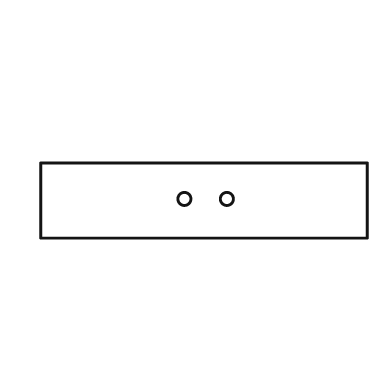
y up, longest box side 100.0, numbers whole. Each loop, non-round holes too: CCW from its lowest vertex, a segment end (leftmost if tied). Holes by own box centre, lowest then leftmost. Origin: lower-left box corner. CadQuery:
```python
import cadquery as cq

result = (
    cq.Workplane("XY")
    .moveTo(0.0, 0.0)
    .lineTo(100.0, 0.0)
    .lineTo(100.0, 23.0)
    .lineTo(0.0, 23.0)
    .close()
    .moveTo(44.0, 12.0)
    .circle(2.0)
    .moveTo(57.0, 12.0)
    .circle(2.0)
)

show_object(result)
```